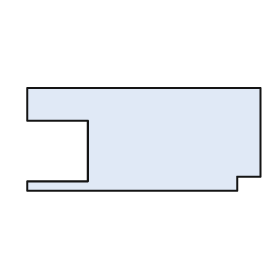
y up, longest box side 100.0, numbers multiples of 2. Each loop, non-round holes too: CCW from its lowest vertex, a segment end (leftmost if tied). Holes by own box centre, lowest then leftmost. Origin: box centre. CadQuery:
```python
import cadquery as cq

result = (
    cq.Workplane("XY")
    .moveTo(-50.0, -22.0)
    .lineTo(40.0, -22.0)
    .lineTo(40.0, -16.0)
    .lineTo(50.0, -16.0)
    .lineTo(50.0, 22.0)
    .lineTo(-50.0, 22.0)
    .lineTo(-50.0, 8.0)
    .lineTo(-24.0, 8.0)
    .lineTo(-24.0, -18.0)
    .lineTo(-50.0, -18.0)
    .close()
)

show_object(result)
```